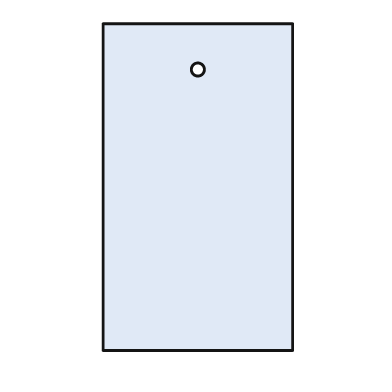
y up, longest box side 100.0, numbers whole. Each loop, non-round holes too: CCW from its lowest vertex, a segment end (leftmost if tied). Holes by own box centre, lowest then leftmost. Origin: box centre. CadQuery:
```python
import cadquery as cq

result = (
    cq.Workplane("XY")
    .moveTo(-29.0, -50.0)
    .lineTo(29.0, -50.0)
    .lineTo(29.0, 50.0)
    .lineTo(-29.0, 50.0)
    .close()
    .moveTo(0.0, 36.0)
    .circle(2.0)
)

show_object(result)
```